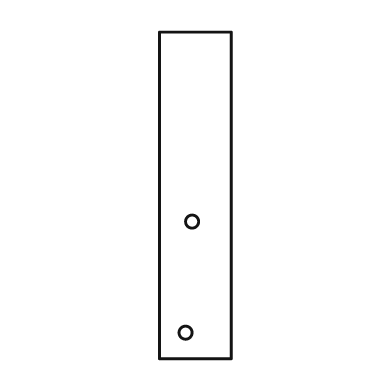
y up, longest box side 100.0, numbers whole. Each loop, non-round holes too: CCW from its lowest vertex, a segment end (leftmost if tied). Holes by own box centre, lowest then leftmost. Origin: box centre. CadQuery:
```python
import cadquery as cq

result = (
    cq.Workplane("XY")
    .moveTo(-11.0, -50.0)
    .lineTo(11.0, -50.0)
    .lineTo(11.0, 50.0)
    .lineTo(-11.0, 50.0)
    .close()
    .moveTo(-3.0, -42.0)
    .circle(2.0)
    .moveTo(-1.0, -8.0)
    .circle(2.0)
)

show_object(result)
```